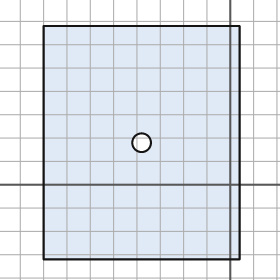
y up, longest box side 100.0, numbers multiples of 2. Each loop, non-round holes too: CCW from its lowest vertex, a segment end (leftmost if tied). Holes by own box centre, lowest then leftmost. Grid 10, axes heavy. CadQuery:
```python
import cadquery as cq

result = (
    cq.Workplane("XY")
    .moveTo(-80.0, -32.0)
    .lineTo(4.0, -32.0)
    .lineTo(4.0, 68.0)
    .lineTo(-80.0, 68.0)
    .close()
    .moveTo(-38.0, 18.0)
    .circle(4.0)
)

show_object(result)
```